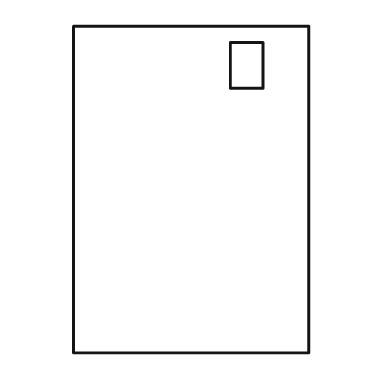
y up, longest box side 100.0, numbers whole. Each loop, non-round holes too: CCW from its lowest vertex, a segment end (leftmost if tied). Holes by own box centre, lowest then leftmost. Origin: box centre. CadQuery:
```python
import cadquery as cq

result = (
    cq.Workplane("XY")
    .moveTo(-36.0, -50.0)
    .lineTo(36.0, -50.0)
    .lineTo(36.0, 50.0)
    .lineTo(-36.0, 50.0)
    .close()
    .moveTo(12.0, 31.0)
    .lineTo(22.0, 31.0)
    .lineTo(22.0, 45.0)
    .lineTo(12.0, 45.0)
    .close()
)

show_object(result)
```